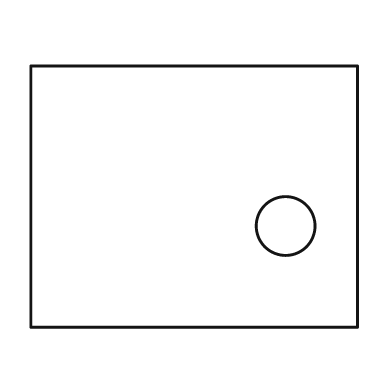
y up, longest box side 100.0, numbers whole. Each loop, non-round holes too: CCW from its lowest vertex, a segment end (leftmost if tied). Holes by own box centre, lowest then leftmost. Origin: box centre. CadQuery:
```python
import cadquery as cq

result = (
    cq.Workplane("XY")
    .moveTo(-50.0, -40.0)
    .lineTo(50.0, -40.0)
    .lineTo(50.0, 40.0)
    .lineTo(-50.0, 40.0)
    .close()
    .moveTo(28.0, -9.0)
    .circle(9.0)
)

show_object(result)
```